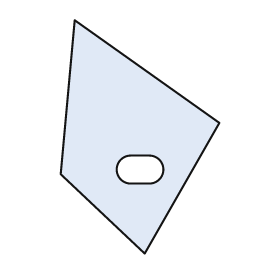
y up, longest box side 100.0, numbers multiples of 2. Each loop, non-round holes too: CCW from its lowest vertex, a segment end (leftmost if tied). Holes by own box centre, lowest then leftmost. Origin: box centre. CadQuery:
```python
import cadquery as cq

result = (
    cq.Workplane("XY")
    .moveTo(2.0, -50.0)
    .lineTo(34.0, 6.0)
    .lineTo(-28.0, 50.0)
    .lineTo(-34.0, -16.0)
    .close()
    .moveTo(-4.0, -20.0)
    .lineTo(4.0, -20.0)
    .threePointArc((10.0, -14.0), (4.0, -8.0))
    .lineTo(-4.0, -8.0)
    .threePointArc((-10.0, -14.0), (-4.0, -20.0))
    .close()
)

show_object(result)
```